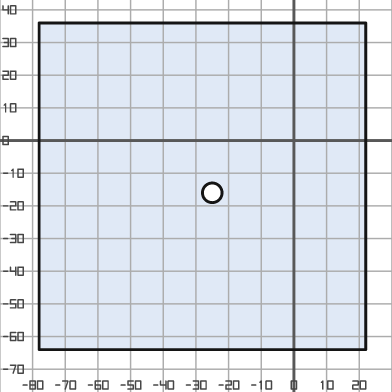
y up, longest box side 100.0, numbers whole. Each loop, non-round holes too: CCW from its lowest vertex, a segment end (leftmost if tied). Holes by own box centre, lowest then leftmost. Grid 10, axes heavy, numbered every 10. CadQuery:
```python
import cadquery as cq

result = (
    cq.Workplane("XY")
    .moveTo(-78.0, -64.0)
    .lineTo(22.0, -64.0)
    .lineTo(22.0, 36.0)
    .lineTo(-78.0, 36.0)
    .close()
    .moveTo(-25.0, -16.0)
    .circle(3.0)
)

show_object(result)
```